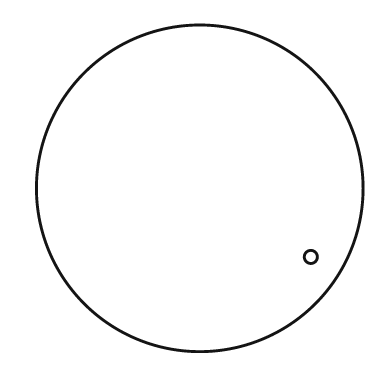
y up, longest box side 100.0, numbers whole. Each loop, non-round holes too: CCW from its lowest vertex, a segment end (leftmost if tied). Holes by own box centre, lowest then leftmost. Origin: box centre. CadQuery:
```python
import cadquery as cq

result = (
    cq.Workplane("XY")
    .moveTo(0.0, 0.0)
    .circle(50.0)
    .moveTo(34.0, -21.0)
    .circle(2.0)
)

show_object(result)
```